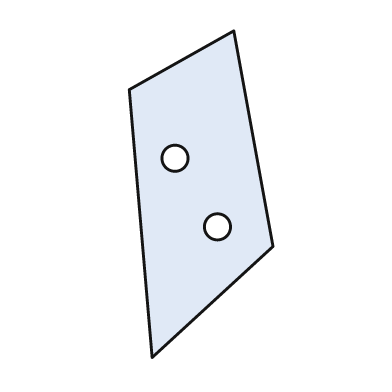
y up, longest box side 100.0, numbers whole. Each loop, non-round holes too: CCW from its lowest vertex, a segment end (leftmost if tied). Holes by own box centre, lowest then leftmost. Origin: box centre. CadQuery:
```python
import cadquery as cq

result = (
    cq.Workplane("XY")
    .moveTo(-15.0, -50.0)
    .lineTo(22.0, -16.0)
    .lineTo(10.0, 50.0)
    .lineTo(-22.0, 32.0)
    .close()
    .moveTo(5.0, -10.0)
    .circle(4.0)
    .moveTo(-8.0, 11.0)
    .circle(4.0)
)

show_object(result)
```